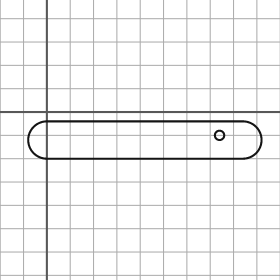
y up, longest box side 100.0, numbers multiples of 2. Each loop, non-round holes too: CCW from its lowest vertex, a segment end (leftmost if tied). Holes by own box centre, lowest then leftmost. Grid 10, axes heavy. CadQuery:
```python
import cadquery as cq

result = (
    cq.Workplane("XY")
    .moveTo(0.0, -20.0)
    .lineTo(84.0, -20.0)
    .threePointArc((92.0, -12.0), (84.0, -4.0))
    .lineTo(0.0, -4.0)
    .threePointArc((-8.0, -12.0), (0.0, -20.0))
    .close()
    .moveTo(74.0, -10.0)
    .circle(2.0)
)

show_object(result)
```